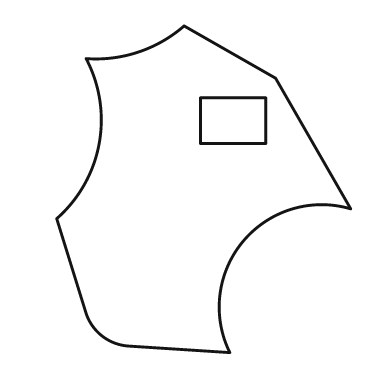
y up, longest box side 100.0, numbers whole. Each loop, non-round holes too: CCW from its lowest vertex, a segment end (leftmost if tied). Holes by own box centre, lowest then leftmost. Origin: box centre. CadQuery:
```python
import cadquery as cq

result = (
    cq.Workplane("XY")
    .moveTo(8.0, -50.0)
    .threePointArc((12.0, -16.0), (45.0, -6.0))
    .lineTo(22.0, 34.0)
    .lineTo(-6.0, 50.0)
    .threePointArc((-20.0, 42.0), (-36.0, 40.0))
    .threePointArc((-32.0, 14.0), (-45.0, -9.0))
    .lineTo(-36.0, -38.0)
    .threePointArc((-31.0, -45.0), (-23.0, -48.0))
    .close()
    .moveTo(-1.0, 14.0)
    .lineTo(19.0, 14.0)
    .lineTo(19.0, 28.0)
    .lineTo(-1.0, 28.0)
    .close()
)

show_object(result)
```